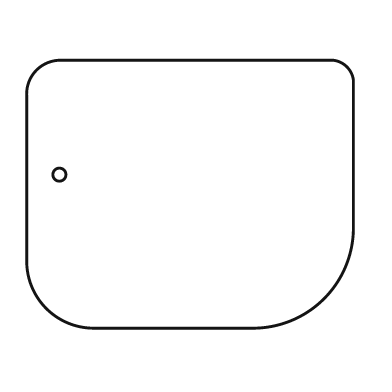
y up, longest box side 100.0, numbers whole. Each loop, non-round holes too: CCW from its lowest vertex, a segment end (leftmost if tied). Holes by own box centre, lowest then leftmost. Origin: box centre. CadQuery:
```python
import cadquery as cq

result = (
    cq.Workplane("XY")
    .moveTo(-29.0, -41.0)
    .lineTo(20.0, -41.0)
    .threePointArc((41.0, -32.0), (50.0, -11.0))
    .lineTo(50.0, 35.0)
    .threePointArc((48.0, 39.0), (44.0, 41.0))
    .lineTo(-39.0, 41.0)
    .threePointArc((-47.0, 38.0), (-50.0, 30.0))
    .lineTo(-50.0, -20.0)
    .threePointArc((-44.0, -35.0), (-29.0, -41.0))
    .close()
    .moveTo(-40.0, 6.0)
    .circle(2.0)
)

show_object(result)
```